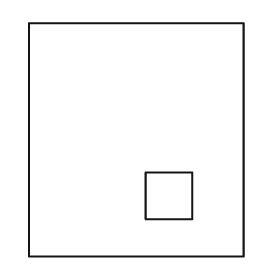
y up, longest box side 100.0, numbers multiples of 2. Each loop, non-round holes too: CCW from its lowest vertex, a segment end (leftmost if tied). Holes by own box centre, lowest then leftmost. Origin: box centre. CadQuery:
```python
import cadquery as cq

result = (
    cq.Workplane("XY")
    .moveTo(-46.0, -50.0)
    .lineTo(46.0, -50.0)
    .lineTo(46.0, 50.0)
    .lineTo(-46.0, 50.0)
    .close()
    .moveTo(4.0, -34.0)
    .lineTo(24.0, -34.0)
    .lineTo(24.0, -14.0)
    .lineTo(4.0, -14.0)
    .close()
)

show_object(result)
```